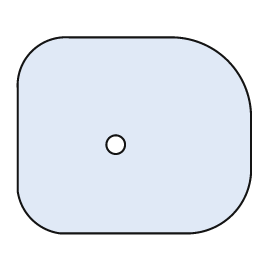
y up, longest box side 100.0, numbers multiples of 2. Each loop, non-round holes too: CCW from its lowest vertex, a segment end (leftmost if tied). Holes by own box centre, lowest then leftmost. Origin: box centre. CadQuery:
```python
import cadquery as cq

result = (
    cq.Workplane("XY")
    .moveTo(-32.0, -42.0)
    .lineTo(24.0, -42.0)
    .threePointArc((42.0, -34.0), (50.0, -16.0))
    .lineTo(50.0, 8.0)
    .threePointArc((40.0, 32.0), (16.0, 42.0))
    .lineTo(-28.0, 42.0)
    .threePointArc((-44.0, 36.0), (-50.0, 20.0))
    .lineTo(-50.0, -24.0)
    .threePointArc((-44.0, -36.0), (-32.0, -42.0))
    .close()
    .moveTo(-8.0, -4.0)
    .circle(4.0)
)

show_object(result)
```